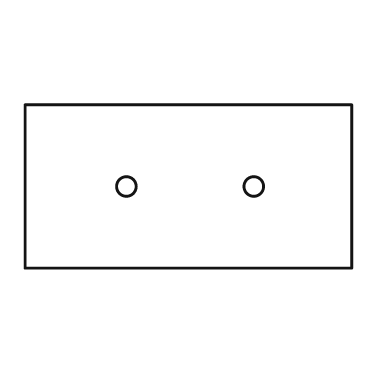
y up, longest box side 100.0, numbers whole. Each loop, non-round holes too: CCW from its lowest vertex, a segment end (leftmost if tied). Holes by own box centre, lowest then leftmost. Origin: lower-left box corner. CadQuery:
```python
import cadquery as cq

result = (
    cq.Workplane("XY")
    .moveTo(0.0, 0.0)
    .lineTo(100.0, 0.0)
    .lineTo(100.0, 50.0)
    .lineTo(0.0, 50.0)
    .close()
    .moveTo(31.0, 25.0)
    .circle(3.0)
    .moveTo(70.0, 25.0)
    .circle(3.0)
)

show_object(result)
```